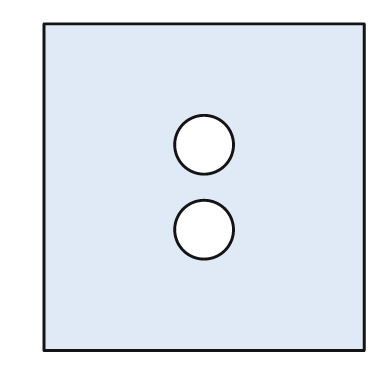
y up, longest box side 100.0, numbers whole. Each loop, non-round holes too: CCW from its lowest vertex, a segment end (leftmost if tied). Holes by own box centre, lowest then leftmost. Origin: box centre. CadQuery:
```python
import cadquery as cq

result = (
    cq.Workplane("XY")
    .moveTo(-49.0, -50.0)
    .lineTo(49.0, -50.0)
    .lineTo(49.0, 50.0)
    .lineTo(-49.0, 50.0)
    .close()
    .moveTo(0.0, -13.0)
    .circle(9.0)
    .moveTo(0.0, 13.0)
    .circle(9.0)
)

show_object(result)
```